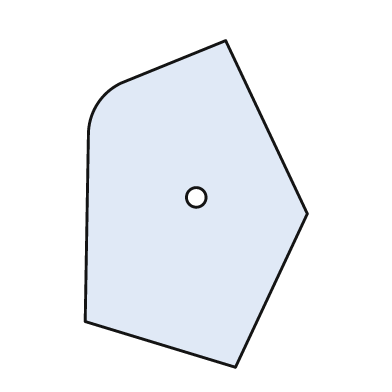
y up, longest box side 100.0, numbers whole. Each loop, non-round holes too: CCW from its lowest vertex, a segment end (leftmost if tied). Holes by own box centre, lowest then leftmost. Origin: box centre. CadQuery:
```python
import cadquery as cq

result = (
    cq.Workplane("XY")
    .moveTo(12.0, -50.0)
    .lineTo(34.0, -3.0)
    .lineTo(9.0, 50.0)
    .lineTo(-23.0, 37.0)
    .threePointArc((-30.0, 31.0), (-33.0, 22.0))
    .lineTo(-34.0, -36.0)
    .close()
    .moveTo(0.0, 2.0)
    .circle(3.0)
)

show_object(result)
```